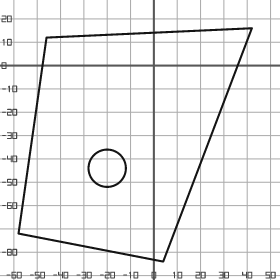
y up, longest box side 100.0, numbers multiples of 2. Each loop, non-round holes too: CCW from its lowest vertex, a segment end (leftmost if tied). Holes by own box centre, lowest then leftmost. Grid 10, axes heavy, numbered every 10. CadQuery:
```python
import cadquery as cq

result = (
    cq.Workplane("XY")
    .moveTo(4.0, -84.0)
    .lineTo(42.0, 16.0)
    .lineTo(-46.0, 12.0)
    .lineTo(-58.0, -72.0)
    .close()
    .moveTo(-20.0, -44.0)
    .circle(8.0)
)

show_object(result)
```